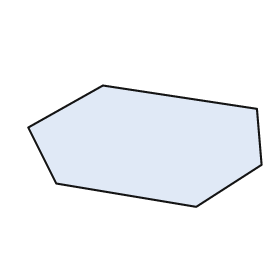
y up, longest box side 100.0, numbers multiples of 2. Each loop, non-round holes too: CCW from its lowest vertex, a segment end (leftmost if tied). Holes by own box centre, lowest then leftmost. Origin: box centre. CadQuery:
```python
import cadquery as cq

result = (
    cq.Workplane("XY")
    .moveTo(22.0, -26.0)
    .lineTo(50.0, -8.0)
    .lineTo(48.0, 16.0)
    .lineTo(-18.0, 26.0)
    .lineTo(-50.0, 8.0)
    .lineTo(-38.0, -16.0)
    .close()
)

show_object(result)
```